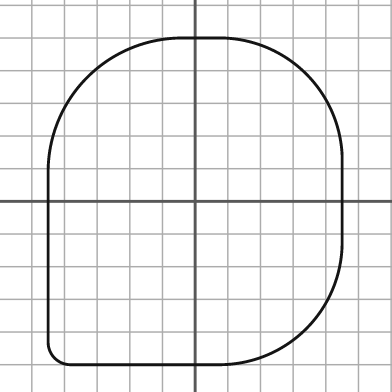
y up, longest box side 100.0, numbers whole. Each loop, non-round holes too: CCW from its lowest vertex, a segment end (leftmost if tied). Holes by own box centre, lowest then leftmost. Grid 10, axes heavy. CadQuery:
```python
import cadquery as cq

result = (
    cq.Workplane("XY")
    .moveTo(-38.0, -50.0)
    .lineTo(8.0, -50.0)
    .threePointArc((34.0, -39.0), (45.0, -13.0))
    .lineTo(45.0, 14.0)
    .threePointArc((34.0, 39.0), (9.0, 50.0))
    .lineTo(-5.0, 50.0)
    .threePointArc((-33.0, 38.0), (-45.0, 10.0))
    .lineTo(-45.0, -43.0)
    .threePointArc((-43.0, -48.0), (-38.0, -50.0))
    .close()
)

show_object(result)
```